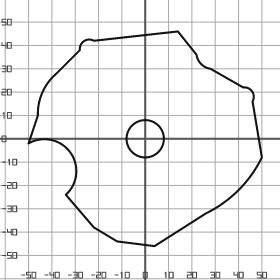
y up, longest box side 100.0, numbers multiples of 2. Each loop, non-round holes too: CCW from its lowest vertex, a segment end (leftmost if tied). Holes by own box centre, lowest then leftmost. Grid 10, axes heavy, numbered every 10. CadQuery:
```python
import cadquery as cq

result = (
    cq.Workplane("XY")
    .moveTo(4.0, -46.0)
    .lineTo(26.0, -32.0)
    .threePointArc((40.0, -22.0), (50.0, -8.0))
    .lineTo(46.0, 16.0)
    .threePointArc((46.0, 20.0), (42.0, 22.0))
    .lineTo(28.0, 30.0)
    .threePointArc((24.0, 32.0), (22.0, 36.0))
    .lineTo(14.0, 46.0)
    .lineTo(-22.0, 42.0)
    .threePointArc((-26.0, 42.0), (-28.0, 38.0))
    .lineTo(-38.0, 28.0)
    .threePointArc((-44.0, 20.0), (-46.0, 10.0))
    .lineTo(-50.0, -2.0)
    .threePointArc((-32.0, -6.0), (-34.0, -24.0))
    .lineTo(-22.0, -38.0)
    .lineTo(-12.0, -44.0)
    .close()
    .moveTo(0.0, 0.0)
    .circle(8.0)
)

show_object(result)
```